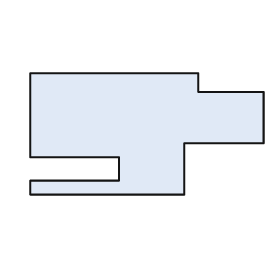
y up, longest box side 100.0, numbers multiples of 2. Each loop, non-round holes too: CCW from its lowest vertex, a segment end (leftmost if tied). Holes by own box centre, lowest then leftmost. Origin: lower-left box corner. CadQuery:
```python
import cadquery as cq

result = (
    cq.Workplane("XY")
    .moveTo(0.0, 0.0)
    .lineTo(66.0, 0.0)
    .lineTo(66.0, 22.0)
    .lineTo(100.0, 22.0)
    .lineTo(100.0, 44.0)
    .lineTo(72.0, 44.0)
    .lineTo(72.0, 52.0)
    .lineTo(0.0, 52.0)
    .lineTo(0.0, 16.0)
    .lineTo(38.0, 16.0)
    .lineTo(38.0, 6.0)
    .lineTo(0.0, 6.0)
    .close()
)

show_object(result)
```